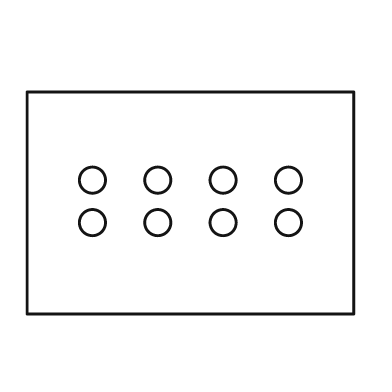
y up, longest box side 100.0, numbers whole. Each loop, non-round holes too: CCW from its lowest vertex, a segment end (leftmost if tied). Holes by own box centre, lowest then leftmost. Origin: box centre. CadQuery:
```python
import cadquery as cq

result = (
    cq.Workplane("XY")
    .moveTo(-50.0, -34.0)
    .lineTo(50.0, -34.0)
    .lineTo(50.0, 34.0)
    .lineTo(-50.0, 34.0)
    .close()
    .moveTo(-30.0, -6.0)
    .circle(4.0)
    .moveTo(-10.0, -6.0)
    .circle(4.0)
    .moveTo(10.0, -6.0)
    .circle(4.0)
    .moveTo(30.0, -6.0)
    .circle(4.0)
    .moveTo(-30.0, 7.0)
    .circle(4.0)
    .moveTo(-10.0, 7.0)
    .circle(4.0)
    .moveTo(10.0, 7.0)
    .circle(4.0)
    .moveTo(30.0, 7.0)
    .circle(4.0)
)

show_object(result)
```